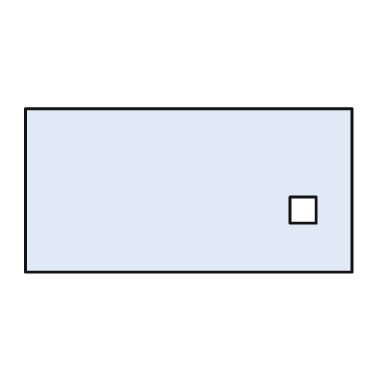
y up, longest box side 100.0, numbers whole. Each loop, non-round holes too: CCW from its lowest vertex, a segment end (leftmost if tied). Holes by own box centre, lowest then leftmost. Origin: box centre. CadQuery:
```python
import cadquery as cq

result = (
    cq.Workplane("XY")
    .moveTo(-50.0, -25.0)
    .lineTo(50.0, -25.0)
    .lineTo(50.0, 25.0)
    .lineTo(-50.0, 25.0)
    .close()
    .moveTo(31.0, -10.0)
    .lineTo(39.0, -10.0)
    .lineTo(39.0, -2.0)
    .lineTo(31.0, -2.0)
    .close()
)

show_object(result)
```